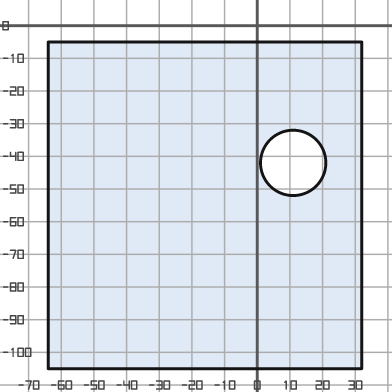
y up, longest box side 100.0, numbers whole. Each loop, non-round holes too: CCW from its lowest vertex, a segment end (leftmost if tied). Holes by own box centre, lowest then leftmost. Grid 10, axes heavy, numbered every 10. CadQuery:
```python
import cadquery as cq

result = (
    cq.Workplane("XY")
    .moveTo(-64.0, -105.0)
    .lineTo(32.0, -105.0)
    .lineTo(32.0, -5.0)
    .lineTo(-64.0, -5.0)
    .close()
    .moveTo(11.0, -42.0)
    .circle(10.0)
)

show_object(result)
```